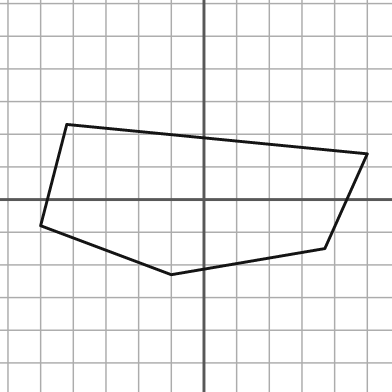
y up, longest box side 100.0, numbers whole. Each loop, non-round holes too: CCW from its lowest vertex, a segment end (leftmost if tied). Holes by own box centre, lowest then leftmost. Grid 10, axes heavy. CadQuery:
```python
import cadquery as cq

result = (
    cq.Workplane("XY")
    .moveTo(-10.0, -23.0)
    .lineTo(37.0, -15.0)
    .lineTo(50.0, 14.0)
    .lineTo(-42.0, 23.0)
    .lineTo(-50.0, -8.0)
    .close()
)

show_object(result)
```